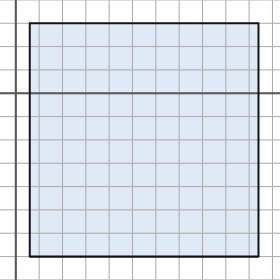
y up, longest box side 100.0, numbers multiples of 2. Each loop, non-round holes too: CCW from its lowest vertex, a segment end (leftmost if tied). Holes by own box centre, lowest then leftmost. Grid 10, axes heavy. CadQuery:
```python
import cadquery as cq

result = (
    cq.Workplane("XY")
    .moveTo(6.0, -70.0)
    .lineTo(104.0, -70.0)
    .lineTo(104.0, 30.0)
    .lineTo(6.0, 30.0)
    .close()
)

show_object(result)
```